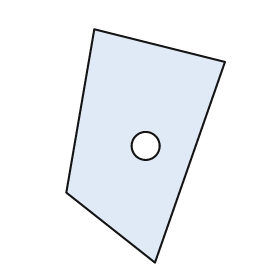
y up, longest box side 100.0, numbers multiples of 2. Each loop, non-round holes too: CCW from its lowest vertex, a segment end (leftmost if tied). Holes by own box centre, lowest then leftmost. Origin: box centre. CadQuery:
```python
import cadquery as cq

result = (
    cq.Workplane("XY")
    .moveTo(4.0, -50.0)
    .lineTo(34.0, 36.0)
    .lineTo(-22.0, 50.0)
    .lineTo(-34.0, -20.0)
    .close()
    .moveTo(0.0, 0.0)
    .circle(6.0)
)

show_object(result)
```